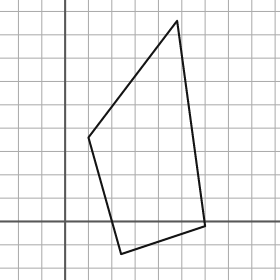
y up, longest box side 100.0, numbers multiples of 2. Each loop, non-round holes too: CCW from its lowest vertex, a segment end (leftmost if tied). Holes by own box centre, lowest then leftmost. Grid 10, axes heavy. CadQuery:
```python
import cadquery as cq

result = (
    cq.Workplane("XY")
    .moveTo(24.0, -14.0)
    .lineTo(60.0, -2.0)
    .lineTo(48.0, 86.0)
    .lineTo(10.0, 36.0)
    .close()
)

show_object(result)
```